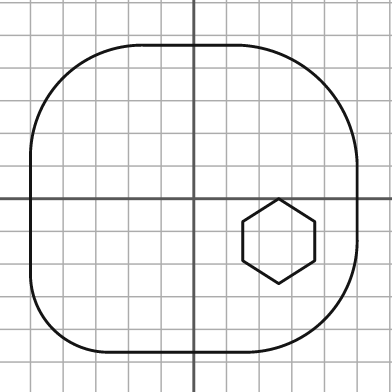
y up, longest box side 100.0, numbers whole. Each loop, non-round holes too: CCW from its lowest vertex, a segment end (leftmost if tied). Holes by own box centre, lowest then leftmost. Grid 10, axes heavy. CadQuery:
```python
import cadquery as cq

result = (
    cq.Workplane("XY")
    .moveTo(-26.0, -47.0)
    .lineTo(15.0, -47.0)
    .threePointArc((40.0, -37.0), (50.0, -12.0))
    .lineTo(50.0, 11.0)
    .threePointArc((39.0, 36.0), (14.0, 47.0))
    .lineTo(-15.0, 47.0)
    .threePointArc((-40.0, 37.0), (-50.0, 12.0))
    .lineTo(-50.0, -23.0)
    .threePointArc((-43.0, -40.0), (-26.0, -47.0))
    .close()
    .moveTo(26.0, -26.0)
    .lineTo(37.0, -19.0)
    .lineTo(37.0, -7.0)
    .lineTo(26.0, 0.0)
    .lineTo(15.0, -7.0)
    .lineTo(15.0, -19.0)
    .close()
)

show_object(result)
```